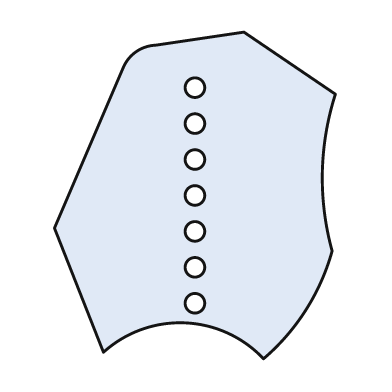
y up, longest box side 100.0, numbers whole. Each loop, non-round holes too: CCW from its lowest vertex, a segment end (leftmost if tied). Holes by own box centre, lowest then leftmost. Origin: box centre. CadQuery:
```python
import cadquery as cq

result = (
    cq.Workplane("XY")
    .moveTo(21.0, -50.0)
    .threePointArc((34.0, -35.0), (42.0, -17.0))
    .threePointArc((39.0, 7.0), (43.0, 31.0))
    .lineTo(15.0, 50.0)
    .lineTo(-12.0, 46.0)
    .threePointArc((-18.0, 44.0), (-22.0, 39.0))
    .lineTo(-43.0, -10.0)
    .lineTo(-28.0, -48.0)
    .threePointArc((-3.0, -39.0), (21.0, -50.0))
    .close()
    .moveTo(0.0, -33.0)
    .circle(3.0)
    .moveTo(0.0, -22.0)
    .circle(3.0)
    .moveTo(0.0, -11.0)
    .circle(3.0)
    .moveTo(0.0, 0.0)
    .circle(3.0)
    .moveTo(0.0, 11.0)
    .circle(3.0)
    .moveTo(0.0, 22.0)
    .circle(3.0)
    .moveTo(0.0, 33.0)
    .circle(3.0)
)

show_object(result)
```